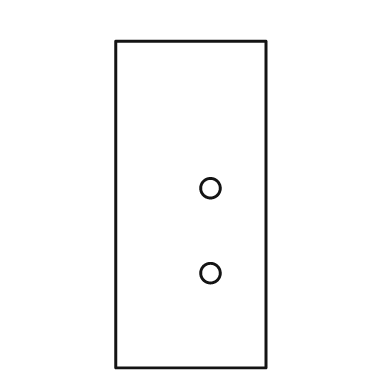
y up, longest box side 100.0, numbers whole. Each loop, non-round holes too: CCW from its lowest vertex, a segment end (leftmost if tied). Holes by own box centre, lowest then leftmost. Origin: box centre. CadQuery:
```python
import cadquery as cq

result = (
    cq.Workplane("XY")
    .moveTo(-23.0, -50.0)
    .lineTo(23.0, -50.0)
    .lineTo(23.0, 50.0)
    .lineTo(-23.0, 50.0)
    .close()
    .moveTo(6.0, -21.0)
    .circle(3.0)
    .moveTo(6.0, 5.0)
    .circle(3.0)
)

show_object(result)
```